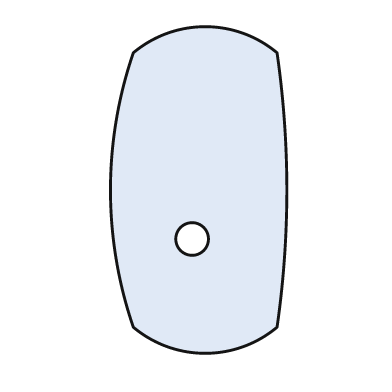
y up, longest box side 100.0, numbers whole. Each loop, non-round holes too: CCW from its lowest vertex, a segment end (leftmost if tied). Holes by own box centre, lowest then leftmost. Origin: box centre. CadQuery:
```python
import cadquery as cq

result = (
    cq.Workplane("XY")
    .moveTo(-20.0, -42.0)
    .threePointArc((2.0, -50.0), (24.0, -42.0))
    .threePointArc((27.0, 0.0), (24.0, 42.0))
    .threePointArc((2.0, 50.0), (-20.0, 42.0))
    .threePointArc((-27.0, 0.0), (-20.0, -42.0))
    .close()
    .moveTo(-2.0, -15.0)
    .circle(5.0)
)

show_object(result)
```